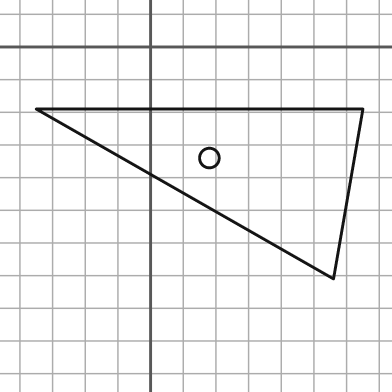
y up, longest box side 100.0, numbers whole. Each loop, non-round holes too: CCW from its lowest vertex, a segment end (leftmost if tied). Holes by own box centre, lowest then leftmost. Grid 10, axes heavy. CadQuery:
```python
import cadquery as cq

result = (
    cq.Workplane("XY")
    .moveTo(56.0, -71.0)
    .lineTo(65.0, -19.0)
    .lineTo(-35.0, -19.0)
    .close()
    .moveTo(18.0, -34.0)
    .circle(3.0)
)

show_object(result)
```